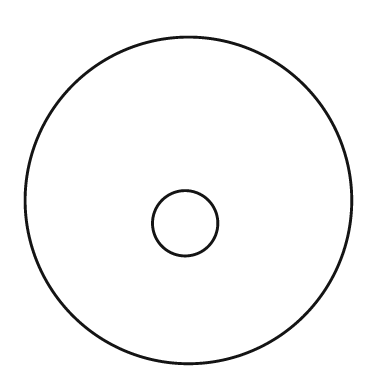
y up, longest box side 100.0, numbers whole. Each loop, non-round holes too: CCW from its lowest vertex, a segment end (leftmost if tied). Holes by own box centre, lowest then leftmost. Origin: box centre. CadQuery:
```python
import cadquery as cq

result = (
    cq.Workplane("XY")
    .moveTo(0.0, 0.0)
    .circle(50.0)
    .moveTo(-1.0, -7.0)
    .circle(10.0)
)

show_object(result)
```